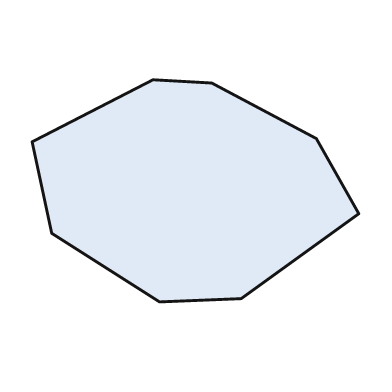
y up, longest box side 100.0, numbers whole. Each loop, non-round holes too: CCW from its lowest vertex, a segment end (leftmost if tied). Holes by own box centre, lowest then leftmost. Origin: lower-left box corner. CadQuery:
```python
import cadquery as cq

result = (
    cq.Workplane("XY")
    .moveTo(39.0, 0.0)
    .lineTo(64.0, 1.0)
    .lineTo(100.0, 27.0)
    .lineTo(87.0, 50.0)
    .lineTo(55.0, 67.0)
    .lineTo(37.0, 68.0)
    .lineTo(0.0, 49.0)
    .lineTo(6.0, 21.0)
    .close()
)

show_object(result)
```